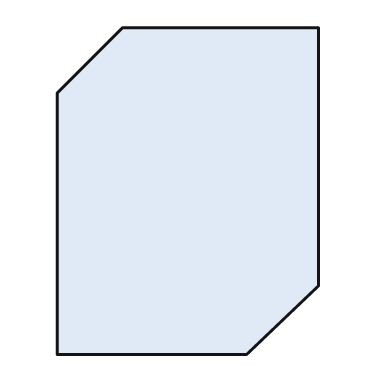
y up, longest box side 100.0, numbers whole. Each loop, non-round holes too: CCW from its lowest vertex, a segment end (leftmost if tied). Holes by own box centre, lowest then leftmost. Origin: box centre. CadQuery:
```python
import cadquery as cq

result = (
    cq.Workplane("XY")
    .moveTo(-40.0, -50.0)
    .lineTo(18.0, -50.0)
    .lineTo(40.0, -29.0)
    .lineTo(40.0, 50.0)
    .lineTo(-20.0, 50.0)
    .lineTo(-40.0, 30.0)
    .close()
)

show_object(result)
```